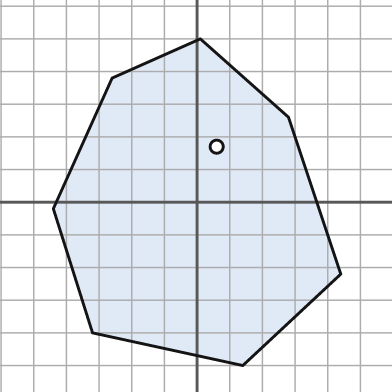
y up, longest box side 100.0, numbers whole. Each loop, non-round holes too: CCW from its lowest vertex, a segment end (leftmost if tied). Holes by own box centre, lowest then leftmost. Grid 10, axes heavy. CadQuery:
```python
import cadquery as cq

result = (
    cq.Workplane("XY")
    .moveTo(14.0, -50.0)
    .lineTo(44.0, -22.0)
    .lineTo(28.0, 26.0)
    .lineTo(1.0, 50.0)
    .lineTo(-26.0, 38.0)
    .lineTo(-44.0, -2.0)
    .lineTo(-32.0, -40.0)
    .close()
    .moveTo(6.0, 17.0)
    .circle(2.0)
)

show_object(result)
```